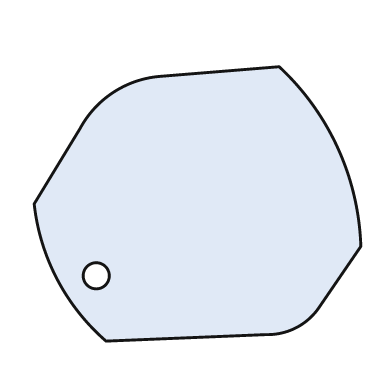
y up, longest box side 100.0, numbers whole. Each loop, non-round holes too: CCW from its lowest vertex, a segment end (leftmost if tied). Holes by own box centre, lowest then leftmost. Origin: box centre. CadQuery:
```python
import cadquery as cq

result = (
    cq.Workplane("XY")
    .moveTo(-28.0, -42.0)
    .lineTo(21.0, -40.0)
    .threePointArc((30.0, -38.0), (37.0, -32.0))
    .lineTo(50.0, -13.0)
    .threePointArc((43.0, 17.0), (25.0, 42.0))
    .lineTo(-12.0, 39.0)
    .threePointArc((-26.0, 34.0), (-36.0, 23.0))
    .lineTo(-50.0, 0.0)
    .threePointArc((-43.0, -23.0), (-28.0, -42.0))
    .close()
    .moveTo(-31.0, -22.0)
    .circle(4.0)
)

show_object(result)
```